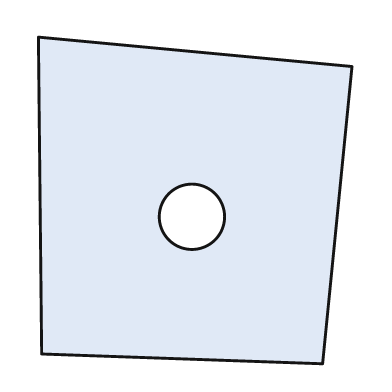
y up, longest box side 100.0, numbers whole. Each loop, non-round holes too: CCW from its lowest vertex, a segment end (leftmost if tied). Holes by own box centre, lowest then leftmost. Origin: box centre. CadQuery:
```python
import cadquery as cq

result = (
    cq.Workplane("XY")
    .moveTo(39.0, -50.0)
    .lineTo(48.0, 41.0)
    .lineTo(-48.0, 50.0)
    .lineTo(-47.0, -47.0)
    .close()
    .moveTo(-1.0, -5.0)
    .circle(10.0)
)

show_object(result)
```